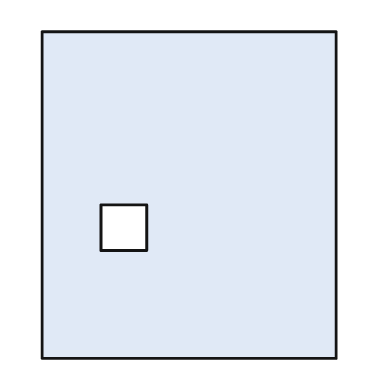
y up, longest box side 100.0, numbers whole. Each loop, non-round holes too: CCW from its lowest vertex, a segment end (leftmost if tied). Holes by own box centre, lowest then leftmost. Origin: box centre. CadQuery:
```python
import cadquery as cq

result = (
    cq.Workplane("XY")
    .moveTo(-45.0, -50.0)
    .lineTo(45.0, -50.0)
    .lineTo(45.0, 50.0)
    .lineTo(-45.0, 50.0)
    .close()
    .moveTo(-27.0, -17.0)
    .lineTo(-13.0, -17.0)
    .lineTo(-13.0, -3.0)
    .lineTo(-27.0, -3.0)
    .close()
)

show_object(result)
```